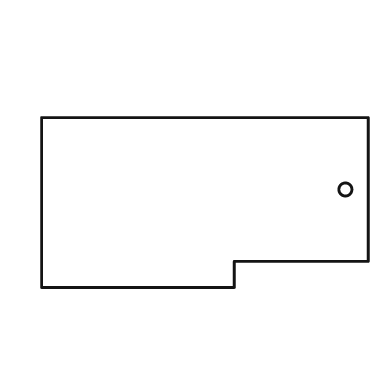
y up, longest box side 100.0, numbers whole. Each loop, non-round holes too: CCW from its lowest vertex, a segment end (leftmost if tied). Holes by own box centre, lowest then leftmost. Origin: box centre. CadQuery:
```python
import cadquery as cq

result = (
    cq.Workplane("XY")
    .moveTo(-50.0, -26.0)
    .lineTo(9.0, -26.0)
    .lineTo(9.0, -18.0)
    .lineTo(50.0, -18.0)
    .lineTo(50.0, 26.0)
    .lineTo(-50.0, 26.0)
    .close()
    .moveTo(43.0, 4.0)
    .circle(2.0)
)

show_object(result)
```